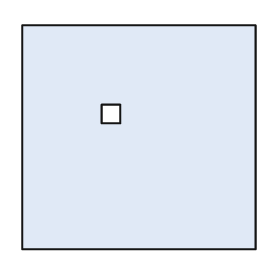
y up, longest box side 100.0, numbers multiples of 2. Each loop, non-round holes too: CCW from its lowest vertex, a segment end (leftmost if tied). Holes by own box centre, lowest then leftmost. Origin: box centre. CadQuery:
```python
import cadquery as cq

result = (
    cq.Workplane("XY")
    .moveTo(-50.0, -48.0)
    .lineTo(50.0, -48.0)
    .lineTo(50.0, 48.0)
    .lineTo(-50.0, 48.0)
    .close()
    .moveTo(-16.0, 6.0)
    .lineTo(-8.0, 6.0)
    .lineTo(-8.0, 14.0)
    .lineTo(-16.0, 14.0)
    .close()
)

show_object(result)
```